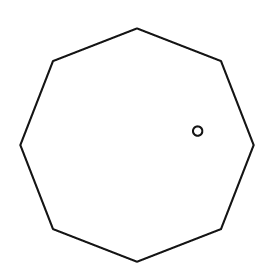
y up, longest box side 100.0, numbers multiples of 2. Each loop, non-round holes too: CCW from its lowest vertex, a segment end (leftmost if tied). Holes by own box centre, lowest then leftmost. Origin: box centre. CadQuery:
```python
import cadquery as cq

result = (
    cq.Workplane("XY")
    .moveTo(0.0, -50.0)
    .lineTo(36.0, -36.0)
    .lineTo(50.0, 0.0)
    .lineTo(36.0, 36.0)
    .lineTo(0.0, 50.0)
    .lineTo(-36.0, 36.0)
    .lineTo(-50.0, 0.0)
    .lineTo(-36.0, -36.0)
    .close()
    .moveTo(26.0, 6.0)
    .circle(2.0)
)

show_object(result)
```